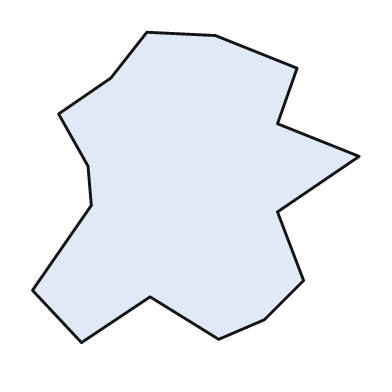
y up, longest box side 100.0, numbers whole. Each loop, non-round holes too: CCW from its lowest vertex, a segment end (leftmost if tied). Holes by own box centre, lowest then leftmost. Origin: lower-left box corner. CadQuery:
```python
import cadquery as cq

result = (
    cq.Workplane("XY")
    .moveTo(15.0, 0.0)
    .lineTo(36.0, 14.0)
    .lineTo(57.0, 1.0)
    .lineTo(71.0, 7.0)
    .lineTo(83.0, 19.0)
    .lineTo(75.0, 40.0)
    .lineTo(100.0, 57.0)
    .lineTo(75.0, 67.0)
    .lineTo(81.0, 84.0)
    .lineTo(56.0, 94.0)
    .lineTo(35.0, 95.0)
    .lineTo(24.0, 81.0)
    .lineTo(8.0, 70.0)
    .lineTo(17.0, 54.0)
    .lineTo(18.0, 42.0)
    .lineTo(0.0, 16.0)
    .close()
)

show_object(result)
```